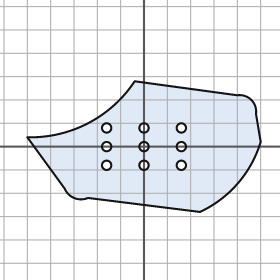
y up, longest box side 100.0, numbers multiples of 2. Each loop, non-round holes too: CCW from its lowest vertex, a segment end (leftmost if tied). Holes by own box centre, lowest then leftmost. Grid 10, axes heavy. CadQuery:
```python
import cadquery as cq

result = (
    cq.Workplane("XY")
    .moveTo(24.0, -28.0)
    .threePointArc((40.0, -16.0), (50.0, 2.0))
    .lineTo(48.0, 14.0)
    .threePointArc((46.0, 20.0), (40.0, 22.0))
    .lineTo(-4.0, 28.0)
    .threePointArc((-24.0, 10.0), (-50.0, 4.0))
    .lineTo(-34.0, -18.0)
    .threePointArc((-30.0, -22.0), (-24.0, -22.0))
    .close()
    .moveTo(-16.0, -8.0)
    .circle(2.0)
    .moveTo(0.0, -8.0)
    .circle(2.0)
    .moveTo(16.0, -8.0)
    .circle(2.0)
    .moveTo(-16.0, 0.0)
    .circle(2.0)
    .moveTo(0.0, 0.0)
    .circle(2.0)
    .moveTo(16.0, 0.0)
    .circle(2.0)
    .moveTo(-16.0, 8.0)
    .circle(2.0)
    .moveTo(0.0, 8.0)
    .circle(2.0)
    .moveTo(16.0, 8.0)
    .circle(2.0)
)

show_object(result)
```